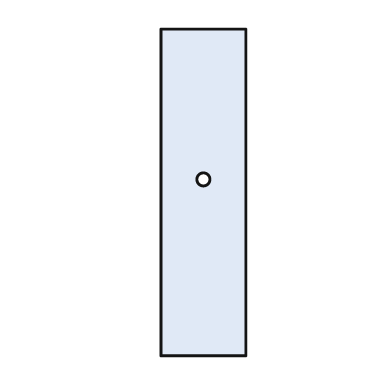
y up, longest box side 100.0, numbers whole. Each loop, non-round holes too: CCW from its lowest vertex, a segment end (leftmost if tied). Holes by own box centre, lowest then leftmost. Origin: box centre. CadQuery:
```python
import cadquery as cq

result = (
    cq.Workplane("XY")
    .moveTo(-13.0, -50.0)
    .lineTo(13.0, -50.0)
    .lineTo(13.0, 50.0)
    .lineTo(-13.0, 50.0)
    .close()
    .moveTo(0.0, 4.0)
    .circle(2.0)
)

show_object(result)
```